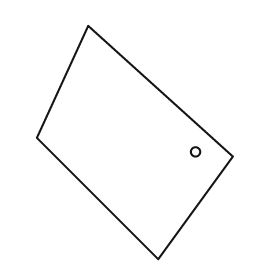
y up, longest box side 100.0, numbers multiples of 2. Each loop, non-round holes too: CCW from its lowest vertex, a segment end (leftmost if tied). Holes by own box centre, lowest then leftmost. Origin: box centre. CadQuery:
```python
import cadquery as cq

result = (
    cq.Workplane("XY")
    .moveTo(10.0, -50.0)
    .lineTo(42.0, -6.0)
    .lineTo(-20.0, 50.0)
    .lineTo(-42.0, 2.0)
    .close()
    .moveTo(26.0, -4.0)
    .circle(2.0)
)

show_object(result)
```